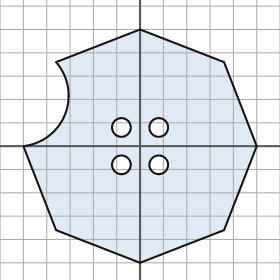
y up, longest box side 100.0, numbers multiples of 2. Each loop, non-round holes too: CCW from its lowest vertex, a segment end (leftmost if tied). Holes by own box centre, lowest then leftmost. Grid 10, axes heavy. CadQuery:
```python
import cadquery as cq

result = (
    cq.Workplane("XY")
    .moveTo(0.0, -50.0)
    .lineTo(36.0, -36.0)
    .lineTo(50.0, 0.0)
    .lineTo(36.0, 36.0)
    .lineTo(0.0, 50.0)
    .lineTo(-36.0, 36.0)
    .threePointArc((-32.0, 14.0), (-50.0, 0.0))
    .lineTo(-36.0, -36.0)
    .close()
    .moveTo(-8.0, -8.0)
    .circle(4.0)
    .moveTo(8.0, -8.0)
    .circle(4.0)
    .moveTo(-8.0, 8.0)
    .circle(4.0)
    .moveTo(8.0, 8.0)
    .circle(4.0)
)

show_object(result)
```